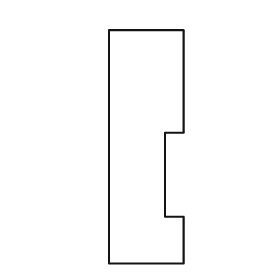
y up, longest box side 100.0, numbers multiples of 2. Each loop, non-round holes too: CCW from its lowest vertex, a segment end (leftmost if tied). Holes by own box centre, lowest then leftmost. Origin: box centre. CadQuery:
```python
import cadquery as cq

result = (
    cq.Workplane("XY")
    .moveTo(-16.0, -50.0)
    .lineTo(16.0, -50.0)
    .lineTo(16.0, -30.0)
    .lineTo(8.0, -30.0)
    .lineTo(8.0, 6.0)
    .lineTo(16.0, 6.0)
    .lineTo(16.0, 50.0)
    .lineTo(-16.0, 50.0)
    .close()
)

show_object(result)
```